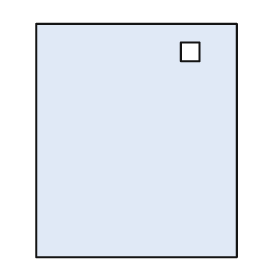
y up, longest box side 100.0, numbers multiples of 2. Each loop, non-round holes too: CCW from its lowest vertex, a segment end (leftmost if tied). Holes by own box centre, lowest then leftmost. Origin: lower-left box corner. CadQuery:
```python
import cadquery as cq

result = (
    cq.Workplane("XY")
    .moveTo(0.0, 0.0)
    .lineTo(86.0, 0.0)
    .lineTo(86.0, 100.0)
    .lineTo(0.0, 100.0)
    .close()
    .moveTo(62.0, 84.0)
    .lineTo(70.0, 84.0)
    .lineTo(70.0, 92.0)
    .lineTo(62.0, 92.0)
    .close()
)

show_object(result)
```